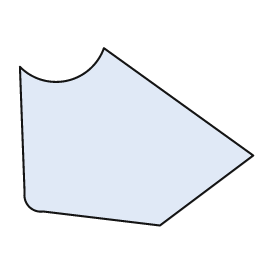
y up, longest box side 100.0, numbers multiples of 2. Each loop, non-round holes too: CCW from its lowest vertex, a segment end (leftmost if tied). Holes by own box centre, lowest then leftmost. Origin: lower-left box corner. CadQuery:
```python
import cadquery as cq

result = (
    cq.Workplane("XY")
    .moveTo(60.0, 0.0)
    .lineTo(100.0, 30.0)
    .lineTo(36.0, 76.0)
    .threePointArc((20.0, 62.0), (0.0, 68.0))
    .lineTo(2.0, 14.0)
    .threePointArc((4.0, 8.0), (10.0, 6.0))
    .close()
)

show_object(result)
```